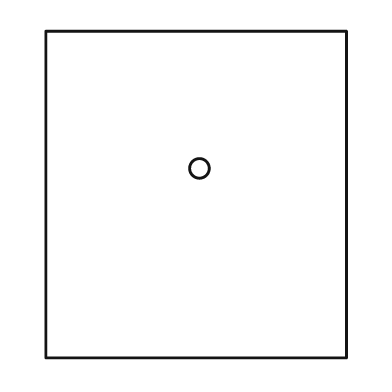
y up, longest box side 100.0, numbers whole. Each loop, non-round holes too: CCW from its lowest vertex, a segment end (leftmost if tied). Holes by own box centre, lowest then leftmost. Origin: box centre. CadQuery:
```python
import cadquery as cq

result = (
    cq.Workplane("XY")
    .moveTo(-46.0, -50.0)
    .lineTo(46.0, -50.0)
    .lineTo(46.0, 50.0)
    .lineTo(-46.0, 50.0)
    .close()
    .moveTo(1.0, 8.0)
    .circle(3.0)
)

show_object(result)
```